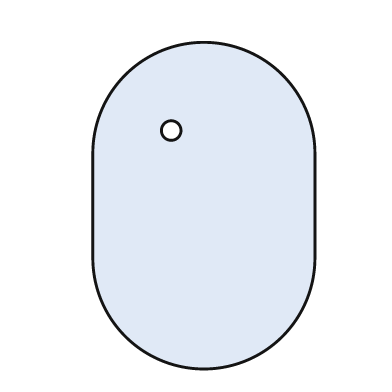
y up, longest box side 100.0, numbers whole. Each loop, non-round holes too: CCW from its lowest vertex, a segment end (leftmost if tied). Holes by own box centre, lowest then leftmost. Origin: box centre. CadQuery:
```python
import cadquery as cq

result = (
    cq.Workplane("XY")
    .moveTo(-34.0, -16.0)
    .threePointArc((0.0, -50.0), (34.0, -16.0))
    .lineTo(34.0, 16.0)
    .threePointArc((0.0, 50.0), (-34.0, 16.0))
    .close()
    .moveTo(-10.0, 23.0)
    .circle(3.0)
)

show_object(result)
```